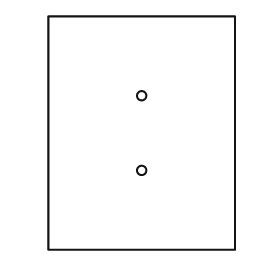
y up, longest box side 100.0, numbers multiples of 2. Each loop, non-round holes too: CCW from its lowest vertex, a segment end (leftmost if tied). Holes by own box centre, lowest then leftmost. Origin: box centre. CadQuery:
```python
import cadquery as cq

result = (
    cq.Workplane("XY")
    .moveTo(-40.0, -50.0)
    .lineTo(40.0, -50.0)
    .lineTo(40.0, 50.0)
    .lineTo(-40.0, 50.0)
    .close()
    .moveTo(0.0, -16.0)
    .circle(2.0)
    .moveTo(0.0, 16.0)
    .circle(2.0)
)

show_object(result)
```